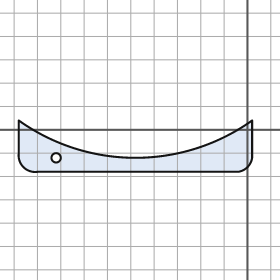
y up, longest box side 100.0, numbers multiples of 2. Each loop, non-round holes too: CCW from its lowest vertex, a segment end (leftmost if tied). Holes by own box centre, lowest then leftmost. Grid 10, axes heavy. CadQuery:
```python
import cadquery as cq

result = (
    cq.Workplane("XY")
    .moveTo(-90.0, -18.0)
    .lineTo(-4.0, -18.0)
    .threePointArc((0.0, -16.0), (2.0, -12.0))
    .lineTo(2.0, 4.0)
    .threePointArc((-48.0, -12.0), (-98.0, 4.0))
    .lineTo(-98.0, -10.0)
    .threePointArc((-96.0, -16.0), (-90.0, -18.0))
    .close()
    .moveTo(-82.0, -12.0)
    .circle(2.0)
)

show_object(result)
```